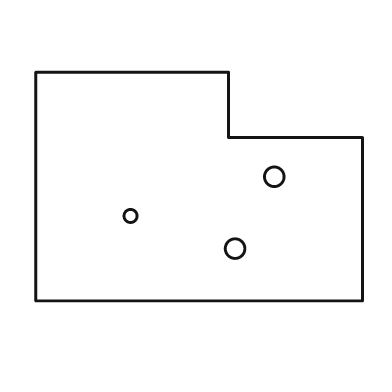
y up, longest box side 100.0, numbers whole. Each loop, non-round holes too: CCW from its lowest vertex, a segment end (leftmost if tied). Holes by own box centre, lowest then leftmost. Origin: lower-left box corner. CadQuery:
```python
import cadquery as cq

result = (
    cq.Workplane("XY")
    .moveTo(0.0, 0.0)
    .lineTo(100.0, 0.0)
    .lineTo(100.0, 50.0)
    .lineTo(59.0, 50.0)
    .lineTo(59.0, 70.0)
    .lineTo(0.0, 70.0)
    .close()
    .moveTo(61.0, 16.0)
    .circle(3.0)
    .moveTo(29.0, 26.0)
    .circle(2.0)
    .moveTo(73.0, 38.0)
    .circle(3.0)
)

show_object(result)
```